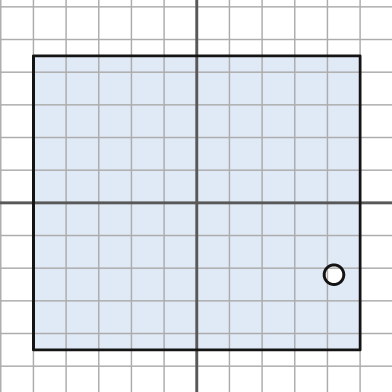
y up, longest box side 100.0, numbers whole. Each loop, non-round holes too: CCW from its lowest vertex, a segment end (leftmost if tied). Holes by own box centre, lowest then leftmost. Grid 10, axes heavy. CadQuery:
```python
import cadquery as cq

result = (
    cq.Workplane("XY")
    .moveTo(-50.0, -45.0)
    .lineTo(50.0, -45.0)
    .lineTo(50.0, 45.0)
    .lineTo(-50.0, 45.0)
    .close()
    .moveTo(42.0, -22.0)
    .circle(3.0)
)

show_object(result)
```